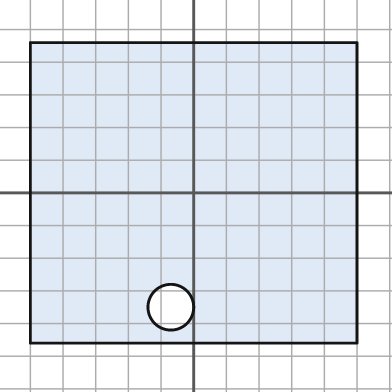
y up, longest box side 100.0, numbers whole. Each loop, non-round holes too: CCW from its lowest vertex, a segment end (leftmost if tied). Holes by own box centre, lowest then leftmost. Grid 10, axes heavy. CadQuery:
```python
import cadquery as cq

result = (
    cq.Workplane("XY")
    .moveTo(-50.0, -46.0)
    .lineTo(50.0, -46.0)
    .lineTo(50.0, 46.0)
    .lineTo(-50.0, 46.0)
    .close()
    .moveTo(-7.0, -35.0)
    .circle(7.0)
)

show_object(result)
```